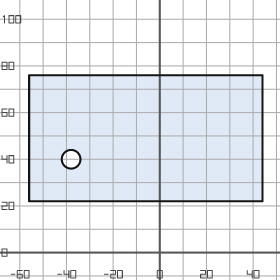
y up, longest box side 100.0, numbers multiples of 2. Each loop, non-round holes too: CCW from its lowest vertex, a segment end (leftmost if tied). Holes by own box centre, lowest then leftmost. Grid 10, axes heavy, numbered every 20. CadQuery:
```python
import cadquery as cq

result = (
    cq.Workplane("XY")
    .moveTo(-56.0, 22.0)
    .lineTo(44.0, 22.0)
    .lineTo(44.0, 76.0)
    .lineTo(-56.0, 76.0)
    .close()
    .moveTo(-38.0, 40.0)
    .circle(4.0)
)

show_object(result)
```